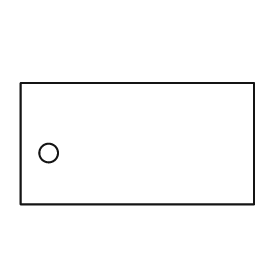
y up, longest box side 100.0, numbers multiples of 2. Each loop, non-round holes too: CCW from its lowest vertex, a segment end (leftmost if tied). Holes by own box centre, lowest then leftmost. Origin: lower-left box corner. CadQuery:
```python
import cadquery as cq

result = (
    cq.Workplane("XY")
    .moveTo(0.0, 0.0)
    .lineTo(100.0, 0.0)
    .lineTo(100.0, 52.0)
    .lineTo(0.0, 52.0)
    .close()
    .moveTo(12.0, 22.0)
    .circle(4.0)
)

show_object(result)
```